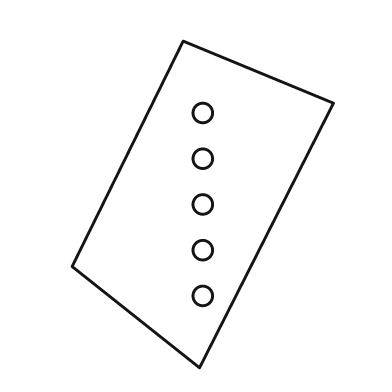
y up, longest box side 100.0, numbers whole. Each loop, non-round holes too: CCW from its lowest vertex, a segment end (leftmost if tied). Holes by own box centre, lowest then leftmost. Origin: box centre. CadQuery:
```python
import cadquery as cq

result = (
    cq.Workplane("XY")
    .moveTo(-1.0, -50.0)
    .lineTo(40.0, 31.0)
    .lineTo(-6.0, 50.0)
    .lineTo(-40.0, -19.0)
    .close()
    .moveTo(0.0, -28.0)
    .circle(3.0)
    .moveTo(0.0, -14.0)
    .circle(3.0)
    .moveTo(0.0, 0.0)
    .circle(3.0)
    .moveTo(0.0, 14.0)
    .circle(3.0)
    .moveTo(0.0, 28.0)
    .circle(3.0)
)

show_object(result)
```